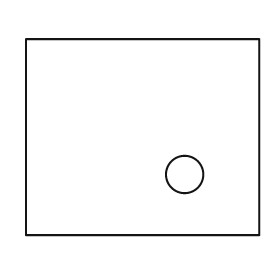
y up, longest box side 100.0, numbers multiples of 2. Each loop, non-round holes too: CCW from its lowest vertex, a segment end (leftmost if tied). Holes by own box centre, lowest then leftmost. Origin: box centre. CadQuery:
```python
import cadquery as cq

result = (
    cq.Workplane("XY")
    .moveTo(-50.0, -42.0)
    .lineTo(50.0, -42.0)
    .lineTo(50.0, 42.0)
    .lineTo(-50.0, 42.0)
    .close()
    .moveTo(18.0, -16.0)
    .circle(8.0)
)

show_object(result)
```